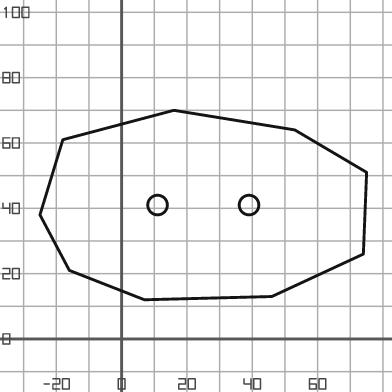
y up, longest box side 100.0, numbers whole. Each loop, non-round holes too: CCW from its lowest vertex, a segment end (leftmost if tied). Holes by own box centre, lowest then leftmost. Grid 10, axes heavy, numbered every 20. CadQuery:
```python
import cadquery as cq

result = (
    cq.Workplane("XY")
    .moveTo(7.0, 12.0)
    .lineTo(46.0, 13.0)
    .lineTo(74.0, 26.0)
    .lineTo(75.0, 51.0)
    .lineTo(53.0, 64.0)
    .lineTo(16.0, 70.0)
    .lineTo(-18.0, 61.0)
    .lineTo(-25.0, 38.0)
    .lineTo(-16.0, 21.0)
    .close()
    .moveTo(11.0, 41.0)
    .circle(3.0)
    .moveTo(39.0, 41.0)
    .circle(3.0)
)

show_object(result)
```